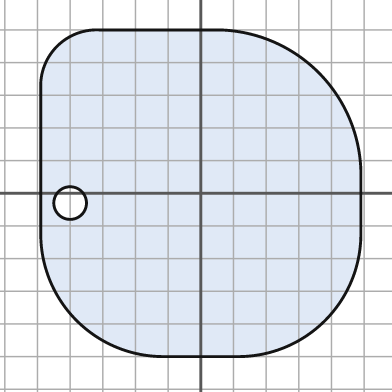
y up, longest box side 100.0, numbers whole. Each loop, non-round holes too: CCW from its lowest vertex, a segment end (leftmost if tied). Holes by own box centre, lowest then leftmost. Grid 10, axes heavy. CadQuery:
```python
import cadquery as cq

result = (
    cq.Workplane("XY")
    .moveTo(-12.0, -50.0)
    .lineTo(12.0, -50.0)
    .threePointArc((38.0, -39.0), (49.0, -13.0))
    .lineTo(49.0, 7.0)
    .threePointArc((36.0, 37.0), (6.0, 50.0))
    .lineTo(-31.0, 50.0)
    .threePointArc((-44.0, 45.0), (-49.0, 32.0))
    .lineTo(-49.0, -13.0)
    .threePointArc((-38.0, -39.0), (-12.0, -50.0))
    .close()
    .moveTo(-40.0, -3.0)
    .circle(5.0)
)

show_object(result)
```